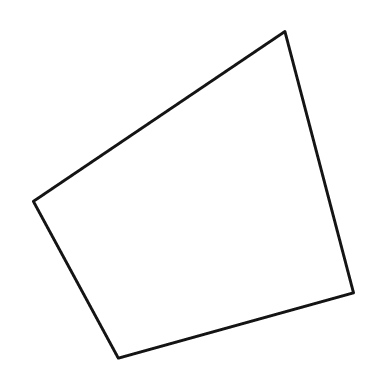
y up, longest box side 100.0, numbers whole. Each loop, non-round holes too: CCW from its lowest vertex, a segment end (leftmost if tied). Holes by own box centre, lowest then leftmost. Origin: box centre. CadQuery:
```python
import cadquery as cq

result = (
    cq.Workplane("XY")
    .moveTo(-23.0, -50.0)
    .lineTo(49.0, -30.0)
    .lineTo(28.0, 50.0)
    .lineTo(-49.0, -2.0)
    .close()
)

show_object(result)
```